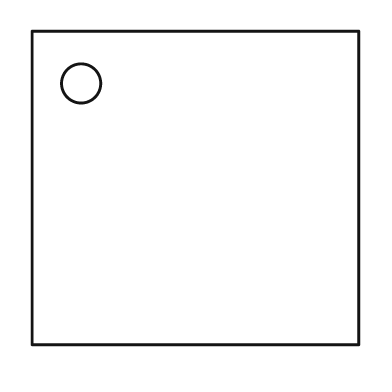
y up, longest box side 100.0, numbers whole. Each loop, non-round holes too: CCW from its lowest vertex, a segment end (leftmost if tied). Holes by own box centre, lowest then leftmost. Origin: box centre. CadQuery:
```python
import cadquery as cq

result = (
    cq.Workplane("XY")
    .moveTo(-50.0, -48.0)
    .lineTo(50.0, -48.0)
    .lineTo(50.0, 48.0)
    .lineTo(-50.0, 48.0)
    .close()
    .moveTo(-35.0, 32.0)
    .circle(6.0)
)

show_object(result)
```